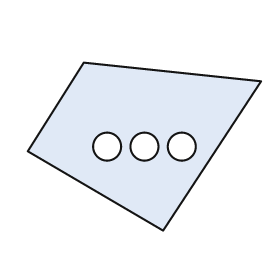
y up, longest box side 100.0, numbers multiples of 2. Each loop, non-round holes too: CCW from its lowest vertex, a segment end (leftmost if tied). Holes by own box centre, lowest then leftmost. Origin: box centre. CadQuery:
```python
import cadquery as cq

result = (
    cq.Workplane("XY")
    .moveTo(8.0, -36.0)
    .lineTo(50.0, 28.0)
    .lineTo(-26.0, 36.0)
    .lineTo(-50.0, -2.0)
    .close()
    .moveTo(-16.0, 0.0)
    .circle(6.0)
    .moveTo(0.0, 0.0)
    .circle(6.0)
    .moveTo(16.0, 0.0)
    .circle(6.0)
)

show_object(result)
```